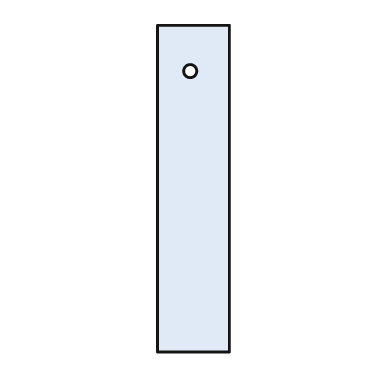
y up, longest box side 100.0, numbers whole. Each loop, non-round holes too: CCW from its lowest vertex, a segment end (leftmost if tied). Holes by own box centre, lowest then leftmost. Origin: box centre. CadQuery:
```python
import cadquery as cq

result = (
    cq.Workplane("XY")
    .moveTo(-11.0, -50.0)
    .lineTo(11.0, -50.0)
    .lineTo(11.0, 50.0)
    .lineTo(-11.0, 50.0)
    .close()
    .moveTo(-1.0, 36.0)
    .circle(2.0)
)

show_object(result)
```